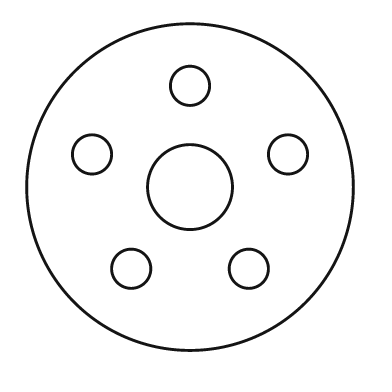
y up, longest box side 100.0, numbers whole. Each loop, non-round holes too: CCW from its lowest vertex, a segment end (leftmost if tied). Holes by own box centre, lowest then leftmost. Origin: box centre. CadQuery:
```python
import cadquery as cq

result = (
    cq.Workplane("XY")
    .moveTo(0.0, 0.0)
    .circle(50.0)
    .moveTo(-18.0, -25.0)
    .circle(6.0)
    .moveTo(18.0, -25.0)
    .circle(6.0)
    .moveTo(0.0, 0.0)
    .circle(13.0)
    .moveTo(-30.0, 10.0)
    .circle(6.0)
    .moveTo(30.0, 10.0)
    .circle(6.0)
    .moveTo(0.0, 31.0)
    .circle(6.0)
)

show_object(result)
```